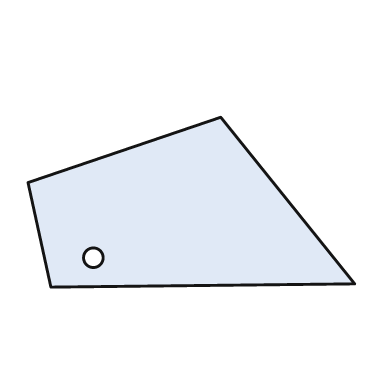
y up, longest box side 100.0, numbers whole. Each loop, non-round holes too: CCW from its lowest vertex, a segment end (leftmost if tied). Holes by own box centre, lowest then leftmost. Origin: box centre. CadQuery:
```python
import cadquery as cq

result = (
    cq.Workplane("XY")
    .moveTo(-43.0, -26.0)
    .lineTo(50.0, -25.0)
    .lineTo(9.0, 26.0)
    .lineTo(-50.0, 6.0)
    .close()
    .moveTo(-30.0, -17.0)
    .circle(3.0)
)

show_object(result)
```